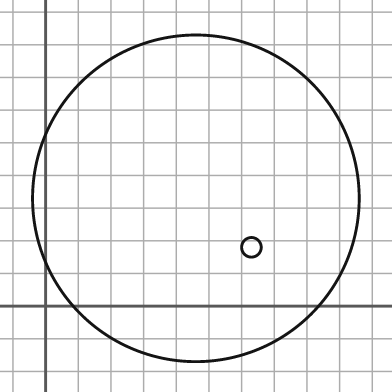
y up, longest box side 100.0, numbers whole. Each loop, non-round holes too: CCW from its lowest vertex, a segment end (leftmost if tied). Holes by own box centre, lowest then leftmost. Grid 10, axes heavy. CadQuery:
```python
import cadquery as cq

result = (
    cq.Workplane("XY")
    .moveTo(46.0, 33.0)
    .circle(50.0)
    .moveTo(63.0, 18.0)
    .circle(3.0)
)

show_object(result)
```